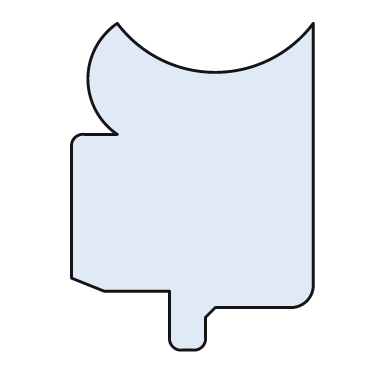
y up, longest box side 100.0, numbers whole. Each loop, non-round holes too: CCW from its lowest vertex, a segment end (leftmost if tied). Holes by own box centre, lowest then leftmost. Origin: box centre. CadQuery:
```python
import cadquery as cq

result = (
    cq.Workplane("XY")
    .moveTo(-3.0, -50.0)
    .lineTo(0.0, -50.0)
    .threePointArc((3.0, -49.0), (4.0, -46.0))
    .lineTo(4.0, -40.0)
    .lineTo(7.0, -37.0)
    .lineTo(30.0, -37.0)
    .threePointArc((35.0, -35.0), (37.0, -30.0))
    .lineTo(37.0, 50.0)
    .threePointArc((7.0, 35.0), (-23.0, 50.0))
    .threePointArc((-32.0, 33.0), (-23.0, 16.0))
    .lineTo(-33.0, 16.0)
    .threePointArc((-36.0, 15.0), (-37.0, 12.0))
    .lineTo(-37.0, -28.0)
    .lineTo(-27.0, -32.0)
    .lineTo(-7.0, -32.0)
    .lineTo(-7.0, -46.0)
    .threePointArc((-6.0, -49.0), (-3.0, -50.0))
    .close()
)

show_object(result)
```